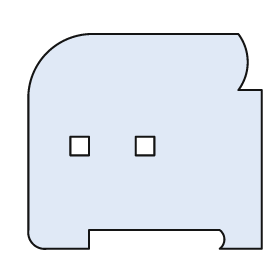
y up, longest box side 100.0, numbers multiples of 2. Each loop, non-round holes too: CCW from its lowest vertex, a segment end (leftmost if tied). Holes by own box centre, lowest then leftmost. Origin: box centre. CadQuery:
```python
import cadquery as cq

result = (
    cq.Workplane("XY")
    .moveTo(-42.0, -46.0)
    .lineTo(-24.0, -46.0)
    .lineTo(-24.0, -38.0)
    .lineTo(32.0, -38.0)
    .threePointArc((34.0, -42.0), (32.0, -46.0))
    .lineTo(50.0, -46.0)
    .lineTo(50.0, 22.0)
    .lineTo(40.0, 22.0)
    .threePointArc((44.0, 34.0), (40.0, 46.0))
    .lineTo(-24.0, 46.0)
    .threePointArc((-42.0, 38.0), (-50.0, 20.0))
    .lineTo(-50.0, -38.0)
    .threePointArc((-48.0, -44.0), (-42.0, -46.0))
    .close()
    .moveTo(-32.0, -6.0)
    .lineTo(-24.0, -6.0)
    .lineTo(-24.0, 2.0)
    .lineTo(-32.0, 2.0)
    .close()
    .moveTo(-4.0, -6.0)
    .lineTo(4.0, -6.0)
    .lineTo(4.0, 2.0)
    .lineTo(-4.0, 2.0)
    .close()
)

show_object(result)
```